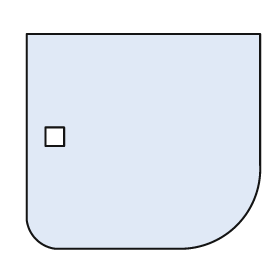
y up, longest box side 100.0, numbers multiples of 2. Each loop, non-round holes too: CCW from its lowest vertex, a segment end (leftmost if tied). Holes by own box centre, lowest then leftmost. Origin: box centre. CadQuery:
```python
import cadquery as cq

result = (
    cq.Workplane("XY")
    .moveTo(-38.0, -46.0)
    .lineTo(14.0, -46.0)
    .threePointArc((40.0, -36.0), (50.0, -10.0))
    .lineTo(50.0, 46.0)
    .lineTo(-50.0, 46.0)
    .lineTo(-50.0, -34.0)
    .threePointArc((-46.0, -42.0), (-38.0, -46.0))
    .close()
    .moveTo(-42.0, -2.0)
    .lineTo(-34.0, -2.0)
    .lineTo(-34.0, 6.0)
    .lineTo(-42.0, 6.0)
    .close()
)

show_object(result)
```